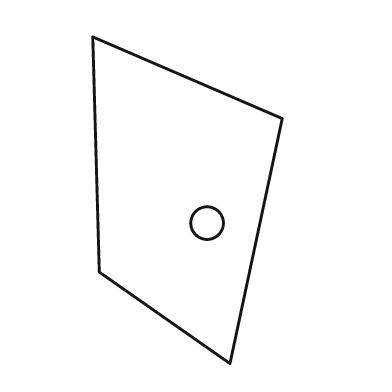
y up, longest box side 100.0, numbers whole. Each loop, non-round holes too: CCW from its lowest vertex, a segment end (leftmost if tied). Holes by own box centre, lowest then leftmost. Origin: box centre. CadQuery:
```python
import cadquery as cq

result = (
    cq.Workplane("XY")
    .moveTo(13.0, -50.0)
    .lineTo(29.0, 25.0)
    .lineTo(-29.0, 50.0)
    .lineTo(-27.0, -22.0)
    .close()
    .moveTo(6.0, -7.0)
    .circle(5.0)
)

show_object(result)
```